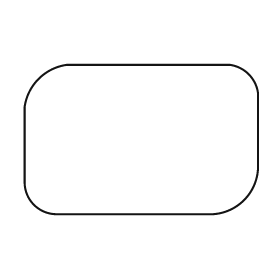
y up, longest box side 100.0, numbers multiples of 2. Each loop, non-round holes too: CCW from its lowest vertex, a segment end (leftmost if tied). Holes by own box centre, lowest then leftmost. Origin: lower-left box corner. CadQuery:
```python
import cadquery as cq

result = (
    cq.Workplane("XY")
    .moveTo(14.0, 0.0)
    .lineTo(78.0, 0.0)
    .threePointArc((94.0, 6.0), (100.0, 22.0))
    .lineTo(100.0, 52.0)
    .threePointArc((96.0, 60.0), (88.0, 64.0))
    .lineTo(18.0, 64.0)
    .threePointArc((6.0, 58.0), (0.0, 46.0))
    .lineTo(0.0, 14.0)
    .threePointArc((4.0, 4.0), (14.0, 0.0))
    .close()
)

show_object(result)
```